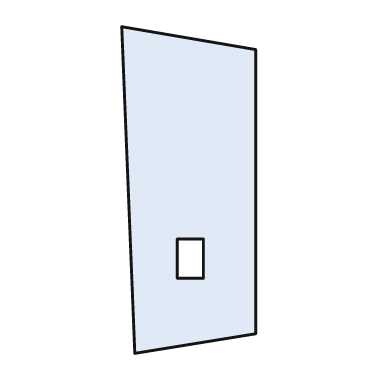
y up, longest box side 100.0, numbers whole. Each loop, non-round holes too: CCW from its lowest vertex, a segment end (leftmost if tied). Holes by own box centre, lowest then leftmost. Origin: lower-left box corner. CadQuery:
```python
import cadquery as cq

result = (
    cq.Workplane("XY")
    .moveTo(4.0, 0.0)
    .lineTo(41.0, 6.0)
    .lineTo(41.0, 93.0)
    .lineTo(0.0, 100.0)
    .close()
    .moveTo(17.0, 23.0)
    .lineTo(25.0, 23.0)
    .lineTo(25.0, 35.0)
    .lineTo(17.0, 35.0)
    .close()
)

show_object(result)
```